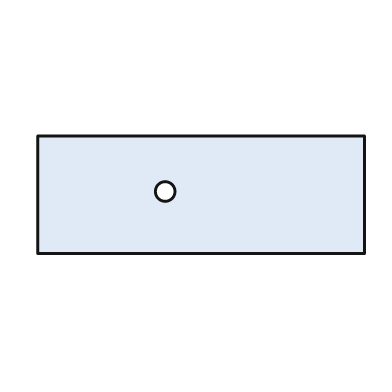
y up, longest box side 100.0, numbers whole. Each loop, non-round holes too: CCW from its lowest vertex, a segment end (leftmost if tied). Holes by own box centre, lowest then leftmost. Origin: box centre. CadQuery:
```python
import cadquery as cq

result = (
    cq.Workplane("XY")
    .moveTo(-50.0, -18.0)
    .lineTo(50.0, -18.0)
    .lineTo(50.0, 18.0)
    .lineTo(-50.0, 18.0)
    .close()
    .moveTo(-11.0, 1.0)
    .circle(3.0)
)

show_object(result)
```